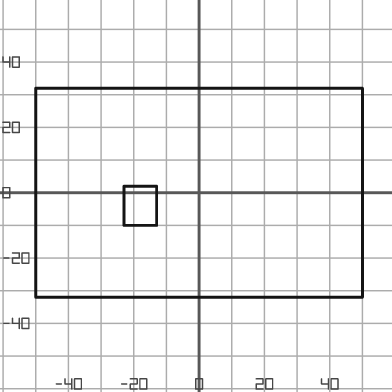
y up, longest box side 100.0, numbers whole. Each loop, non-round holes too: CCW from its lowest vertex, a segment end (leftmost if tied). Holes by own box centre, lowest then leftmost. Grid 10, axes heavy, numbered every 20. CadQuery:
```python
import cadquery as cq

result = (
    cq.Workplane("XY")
    .moveTo(-50.0, -32.0)
    .lineTo(50.0, -32.0)
    .lineTo(50.0, 32.0)
    .lineTo(-50.0, 32.0)
    .close()
    .moveTo(-23.0, -10.0)
    .lineTo(-13.0, -10.0)
    .lineTo(-13.0, 2.0)
    .lineTo(-23.0, 2.0)
    .close()
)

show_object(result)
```